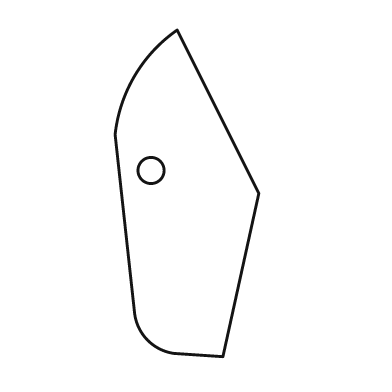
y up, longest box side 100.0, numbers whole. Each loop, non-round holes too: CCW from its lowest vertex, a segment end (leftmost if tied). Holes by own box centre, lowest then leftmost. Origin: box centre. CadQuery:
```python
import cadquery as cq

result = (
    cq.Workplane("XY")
    .moveTo(11.0, -50.0)
    .lineTo(22.0, 0.0)
    .lineTo(-3.0, 50.0)
    .threePointArc((-16.0, 36.0), (-22.0, 18.0))
    .lineTo(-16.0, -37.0)
    .threePointArc((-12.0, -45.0), (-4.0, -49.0))
    .close()
    .moveTo(-11.0, 7.0)
    .circle(4.0)
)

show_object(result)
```